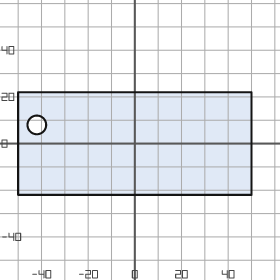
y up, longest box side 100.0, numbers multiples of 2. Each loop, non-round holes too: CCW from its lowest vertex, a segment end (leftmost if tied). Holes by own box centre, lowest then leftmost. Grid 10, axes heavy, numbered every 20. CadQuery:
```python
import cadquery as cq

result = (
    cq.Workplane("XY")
    .moveTo(-50.0, -22.0)
    .lineTo(50.0, -22.0)
    .lineTo(50.0, 22.0)
    .lineTo(-50.0, 22.0)
    .close()
    .moveTo(-42.0, 8.0)
    .circle(4.0)
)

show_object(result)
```